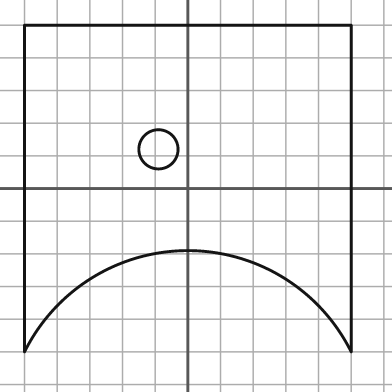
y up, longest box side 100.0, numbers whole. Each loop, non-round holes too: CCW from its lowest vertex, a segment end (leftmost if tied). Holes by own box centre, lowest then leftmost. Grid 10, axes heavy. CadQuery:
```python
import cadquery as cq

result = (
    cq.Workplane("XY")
    .moveTo(-50.0, -50.0)
    .threePointArc((0.0, -19.0), (50.0, -50.0))
    .lineTo(50.0, 50.0)
    .lineTo(-50.0, 50.0)
    .close()
    .moveTo(-9.0, 12.0)
    .circle(6.0)
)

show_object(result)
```